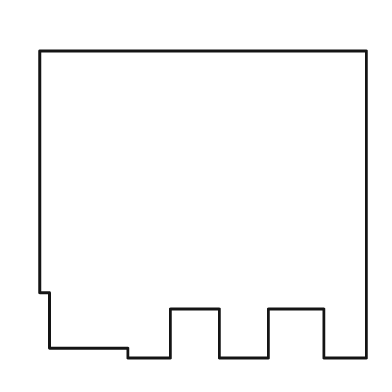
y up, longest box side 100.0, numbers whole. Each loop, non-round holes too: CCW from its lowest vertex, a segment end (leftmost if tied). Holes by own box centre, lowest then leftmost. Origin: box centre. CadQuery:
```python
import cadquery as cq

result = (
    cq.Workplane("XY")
    .moveTo(-23.0, -47.0)
    .lineTo(-10.0, -47.0)
    .lineTo(-10.0, -32.0)
    .lineTo(5.0, -32.0)
    .lineTo(5.0, -47.0)
    .lineTo(20.0, -47.0)
    .lineTo(20.0, -32.0)
    .lineTo(37.0, -32.0)
    .lineTo(37.0, -47.0)
    .lineTo(50.0, -47.0)
    .lineTo(50.0, 47.0)
    .lineTo(-50.0, 47.0)
    .lineTo(-50.0, -27.0)
    .lineTo(-47.0, -27.0)
    .lineTo(-47.0, -44.0)
    .lineTo(-23.0, -44.0)
    .close()
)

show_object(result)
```